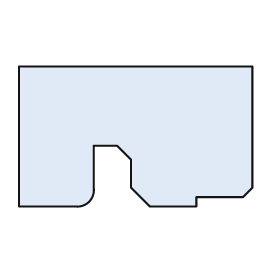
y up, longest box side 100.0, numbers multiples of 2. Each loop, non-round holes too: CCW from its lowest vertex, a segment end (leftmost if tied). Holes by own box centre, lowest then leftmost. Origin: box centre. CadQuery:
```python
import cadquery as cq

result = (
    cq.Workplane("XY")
    .moveTo(-50.0, -30.0)
    .lineTo(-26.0, -30.0)
    .threePointArc((-20.0, -28.0), (-18.0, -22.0))
    .lineTo(-18.0, -4.0)
    .lineTo(-8.0, -4.0)
    .lineTo(-2.0, -10.0)
    .lineTo(-2.0, -22.0)
    .lineTo(6.0, -30.0)
    .lineTo(26.0, -30.0)
    .lineTo(26.0, -26.0)
    .lineTo(46.0, -26.0)
    .lineTo(50.0, -22.0)
    .lineTo(50.0, 30.0)
    .lineTo(-50.0, 30.0)
    .close()
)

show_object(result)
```